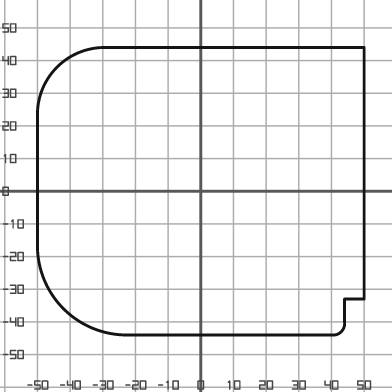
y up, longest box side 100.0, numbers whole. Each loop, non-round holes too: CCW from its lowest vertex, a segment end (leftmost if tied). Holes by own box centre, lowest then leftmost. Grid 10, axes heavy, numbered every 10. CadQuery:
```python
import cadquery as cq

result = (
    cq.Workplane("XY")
    .moveTo(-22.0, -44.0)
    .lineTo(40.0, -44.0)
    .threePointArc((43.0, -43.0), (44.0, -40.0))
    .lineTo(44.0, -33.0)
    .lineTo(50.0, -33.0)
    .lineTo(50.0, 44.0)
    .lineTo(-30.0, 44.0)
    .threePointArc((-44.0, 38.0), (-50.0, 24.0))
    .lineTo(-50.0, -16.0)
    .threePointArc((-42.0, -36.0), (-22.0, -44.0))
    .close()
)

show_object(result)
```